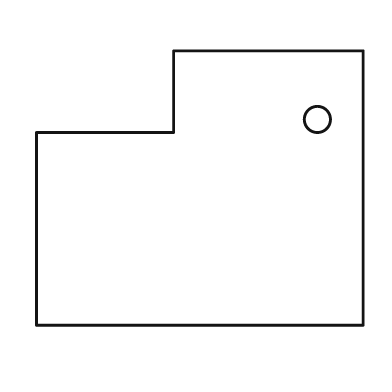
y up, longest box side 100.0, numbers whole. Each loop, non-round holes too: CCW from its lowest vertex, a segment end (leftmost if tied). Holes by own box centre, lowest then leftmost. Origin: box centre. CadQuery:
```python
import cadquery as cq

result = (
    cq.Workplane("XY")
    .moveTo(-50.0, -42.0)
    .lineTo(50.0, -42.0)
    .lineTo(50.0, 42.0)
    .lineTo(-8.0, 42.0)
    .lineTo(-8.0, 17.0)
    .lineTo(-50.0, 17.0)
    .close()
    .moveTo(36.0, 21.0)
    .circle(4.0)
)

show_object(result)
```